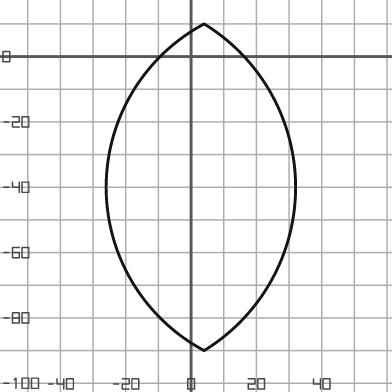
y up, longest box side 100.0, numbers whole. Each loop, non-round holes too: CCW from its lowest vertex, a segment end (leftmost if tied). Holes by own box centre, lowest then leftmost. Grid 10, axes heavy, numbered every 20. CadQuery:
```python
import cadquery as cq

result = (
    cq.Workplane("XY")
    .moveTo(4.0, -90.0)
    .threePointArc((32.0, -40.0), (4.0, 10.0))
    .threePointArc((-26.0, -40.0), (4.0, -90.0))
    .close()
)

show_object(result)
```